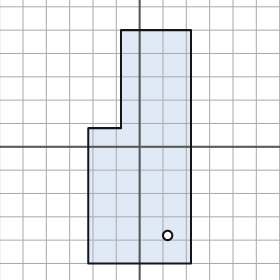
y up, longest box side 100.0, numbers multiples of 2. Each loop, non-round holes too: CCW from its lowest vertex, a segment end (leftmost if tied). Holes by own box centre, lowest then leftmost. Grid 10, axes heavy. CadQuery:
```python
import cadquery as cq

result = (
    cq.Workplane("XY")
    .moveTo(-22.0, -50.0)
    .lineTo(22.0, -50.0)
    .lineTo(22.0, 50.0)
    .lineTo(-8.0, 50.0)
    .lineTo(-8.0, 8.0)
    .lineTo(-22.0, 8.0)
    .close()
    .moveTo(12.0, -38.0)
    .circle(2.0)
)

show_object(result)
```